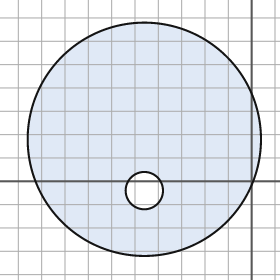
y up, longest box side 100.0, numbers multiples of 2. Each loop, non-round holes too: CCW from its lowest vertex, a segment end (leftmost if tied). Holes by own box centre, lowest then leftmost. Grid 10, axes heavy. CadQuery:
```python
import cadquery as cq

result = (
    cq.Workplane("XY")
    .moveTo(-46.0, 18.0)
    .circle(50.0)
    .moveTo(-46.0, -4.0)
    .circle(8.0)
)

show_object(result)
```